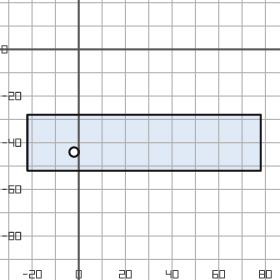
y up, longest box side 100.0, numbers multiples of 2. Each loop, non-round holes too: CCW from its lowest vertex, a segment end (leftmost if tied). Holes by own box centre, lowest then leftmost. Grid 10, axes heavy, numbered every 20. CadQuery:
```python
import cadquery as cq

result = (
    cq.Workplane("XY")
    .moveTo(-22.0, -52.0)
    .lineTo(78.0, -52.0)
    .lineTo(78.0, -28.0)
    .lineTo(-22.0, -28.0)
    .close()
    .moveTo(-2.0, -44.0)
    .circle(2.0)
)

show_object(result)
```